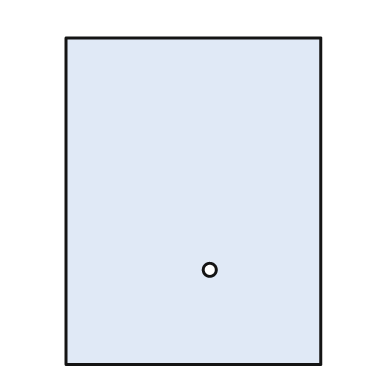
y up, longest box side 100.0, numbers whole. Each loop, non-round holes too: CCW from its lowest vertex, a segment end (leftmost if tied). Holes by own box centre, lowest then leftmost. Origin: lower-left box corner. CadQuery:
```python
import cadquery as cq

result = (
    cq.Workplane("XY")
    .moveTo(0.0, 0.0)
    .lineTo(78.0, 0.0)
    .lineTo(78.0, 100.0)
    .lineTo(0.0, 100.0)
    .close()
    .moveTo(44.0, 29.0)
    .circle(2.0)
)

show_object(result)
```